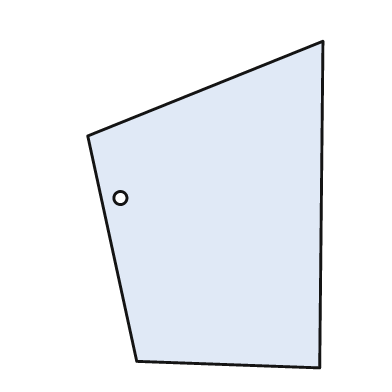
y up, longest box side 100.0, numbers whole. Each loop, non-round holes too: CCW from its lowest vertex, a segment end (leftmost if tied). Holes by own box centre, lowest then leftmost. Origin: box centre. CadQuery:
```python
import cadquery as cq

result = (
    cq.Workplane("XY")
    .moveTo(35.0, -50.0)
    .lineTo(36.0, 50.0)
    .lineTo(-36.0, 21.0)
    .lineTo(-21.0, -48.0)
    .close()
    .moveTo(-26.0, 2.0)
    .circle(2.0)
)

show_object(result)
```